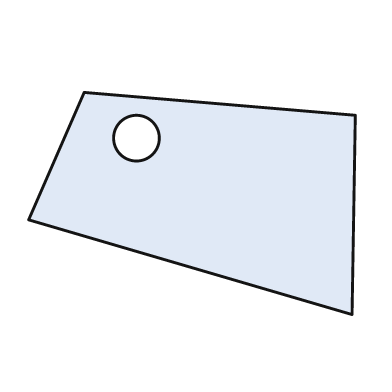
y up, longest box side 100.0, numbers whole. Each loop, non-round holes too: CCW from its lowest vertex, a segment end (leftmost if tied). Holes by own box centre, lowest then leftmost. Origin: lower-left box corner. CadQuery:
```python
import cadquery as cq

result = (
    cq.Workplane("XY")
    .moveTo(99.0, 0.0)
    .lineTo(100.0, 61.0)
    .lineTo(17.0, 68.0)
    .lineTo(0.0, 29.0)
    .close()
    .moveTo(33.0, 54.0)
    .circle(7.0)
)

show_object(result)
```